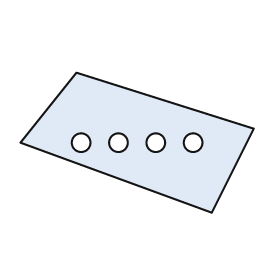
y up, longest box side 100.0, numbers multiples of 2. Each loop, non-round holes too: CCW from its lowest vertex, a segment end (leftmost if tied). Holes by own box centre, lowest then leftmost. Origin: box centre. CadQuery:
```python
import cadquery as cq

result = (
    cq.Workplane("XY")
    .moveTo(32.0, -30.0)
    .lineTo(50.0, 6.0)
    .lineTo(-26.0, 30.0)
    .lineTo(-50.0, 0.0)
    .close()
    .moveTo(-24.0, 0.0)
    .circle(4.0)
    .moveTo(-8.0, 0.0)
    .circle(4.0)
    .moveTo(8.0, 0.0)
    .circle(4.0)
    .moveTo(24.0, 0.0)
    .circle(4.0)
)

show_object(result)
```